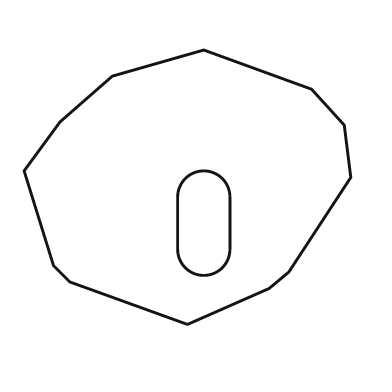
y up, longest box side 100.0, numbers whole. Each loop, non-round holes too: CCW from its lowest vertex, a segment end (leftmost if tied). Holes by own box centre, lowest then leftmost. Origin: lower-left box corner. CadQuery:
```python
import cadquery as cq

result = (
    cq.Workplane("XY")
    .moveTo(50.0, 0.0)
    .lineTo(75.0, 11.0)
    .lineTo(81.0, 16.0)
    .lineTo(100.0, 45.0)
    .lineTo(98.0, 61.0)
    .lineTo(88.0, 72.0)
    .lineTo(55.0, 84.0)
    .lineTo(27.0, 76.0)
    .lineTo(11.0, 62.0)
    .lineTo(0.0, 47.0)
    .lineTo(9.0, 18.0)
    .lineTo(14.0, 13.0)
    .close()
    .moveTo(47.0, 23.0)
    .threePointArc((55.0, 15.0), (63.0, 23.0))
    .lineTo(63.0, 39.0)
    .threePointArc((55.0, 47.0), (47.0, 39.0))
    .close()
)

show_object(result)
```